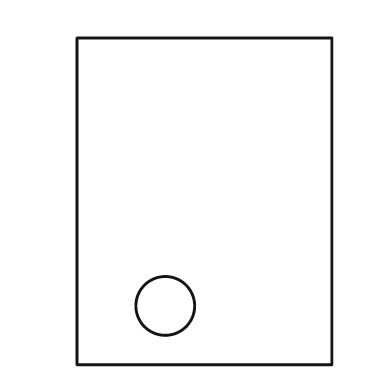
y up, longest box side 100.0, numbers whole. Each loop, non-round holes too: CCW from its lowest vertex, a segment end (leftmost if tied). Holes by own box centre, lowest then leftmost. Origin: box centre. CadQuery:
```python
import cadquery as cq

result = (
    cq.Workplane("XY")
    .moveTo(-39.0, -50.0)
    .lineTo(39.0, -50.0)
    .lineTo(39.0, 50.0)
    .lineTo(-39.0, 50.0)
    .close()
    .moveTo(-12.0, -32.0)
    .circle(9.0)
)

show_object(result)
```